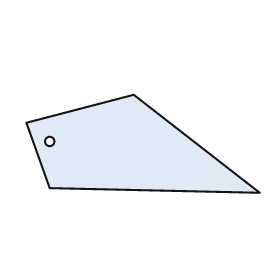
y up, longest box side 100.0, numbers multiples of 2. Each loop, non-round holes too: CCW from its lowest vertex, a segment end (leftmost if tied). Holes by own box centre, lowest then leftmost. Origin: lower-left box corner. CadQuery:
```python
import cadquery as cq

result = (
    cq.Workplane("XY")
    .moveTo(100.0, 0.0)
    .lineTo(46.0, 42.0)
    .lineTo(0.0, 30.0)
    .lineTo(10.0, 2.0)
    .close()
    .moveTo(10.0, 22.0)
    .circle(2.0)
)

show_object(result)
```